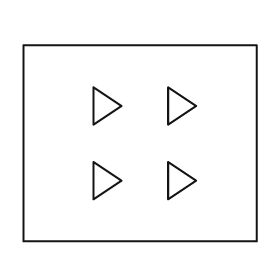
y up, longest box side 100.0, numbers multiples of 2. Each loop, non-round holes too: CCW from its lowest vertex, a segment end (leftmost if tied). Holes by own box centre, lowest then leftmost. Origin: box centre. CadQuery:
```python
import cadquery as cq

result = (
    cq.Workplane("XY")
    .moveTo(-50.0, -42.0)
    .lineTo(50.0, -42.0)
    .lineTo(50.0, 42.0)
    .lineTo(-50.0, 42.0)
    .close()
    .moveTo(-20.0, -24.0)
    .lineTo(-8.0, -16.0)
    .lineTo(-20.0, -8.0)
    .close()
    .moveTo(12.0, -24.0)
    .lineTo(24.0, -16.0)
    .lineTo(12.0, -8.0)
    .close()
    .moveTo(-20.0, 8.0)
    .lineTo(-8.0, 16.0)
    .lineTo(-20.0, 24.0)
    .close()
    .moveTo(12.0, 8.0)
    .lineTo(24.0, 16.0)
    .lineTo(12.0, 24.0)
    .close()
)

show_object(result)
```